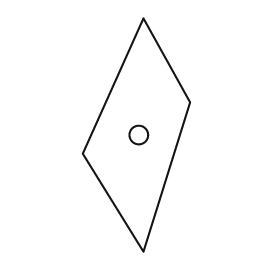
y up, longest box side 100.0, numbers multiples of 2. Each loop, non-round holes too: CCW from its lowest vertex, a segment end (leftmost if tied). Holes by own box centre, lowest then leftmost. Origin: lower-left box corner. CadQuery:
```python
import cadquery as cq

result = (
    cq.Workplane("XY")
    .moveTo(26.0, 0.0)
    .lineTo(46.0, 64.0)
    .lineTo(26.0, 100.0)
    .lineTo(0.0, 42.0)
    .close()
    .moveTo(24.0, 50.0)
    .circle(4.0)
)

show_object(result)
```